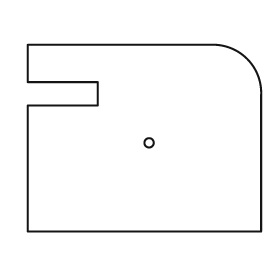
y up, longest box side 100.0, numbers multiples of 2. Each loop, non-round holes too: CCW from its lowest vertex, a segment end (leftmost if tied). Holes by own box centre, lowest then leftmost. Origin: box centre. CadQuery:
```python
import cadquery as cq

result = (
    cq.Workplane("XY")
    .moveTo(-50.0, -40.0)
    .lineTo(50.0, -40.0)
    .lineTo(50.0, 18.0)
    .threePointArc((44.0, 34.0), (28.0, 40.0))
    .lineTo(-50.0, 40.0)
    .lineTo(-50.0, 24.0)
    .lineTo(-20.0, 24.0)
    .lineTo(-20.0, 14.0)
    .lineTo(-50.0, 14.0)
    .close()
    .moveTo(2.0, -2.0)
    .circle(2.0)
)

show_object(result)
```